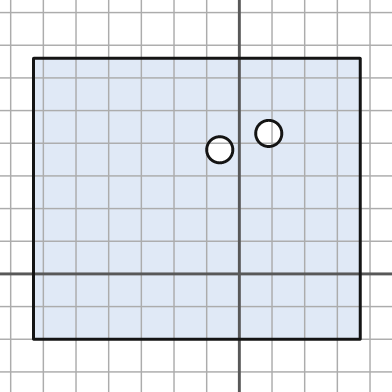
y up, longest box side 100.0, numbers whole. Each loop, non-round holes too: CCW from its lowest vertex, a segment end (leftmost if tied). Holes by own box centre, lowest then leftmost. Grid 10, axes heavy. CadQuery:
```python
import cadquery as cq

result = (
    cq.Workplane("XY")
    .moveTo(-63.0, -20.0)
    .lineTo(37.0, -20.0)
    .lineTo(37.0, 66.0)
    .lineTo(-63.0, 66.0)
    .close()
    .moveTo(-6.0, 38.0)
    .circle(4.0)
    .moveTo(9.0, 43.0)
    .circle(4.0)
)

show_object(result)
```